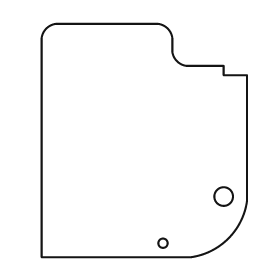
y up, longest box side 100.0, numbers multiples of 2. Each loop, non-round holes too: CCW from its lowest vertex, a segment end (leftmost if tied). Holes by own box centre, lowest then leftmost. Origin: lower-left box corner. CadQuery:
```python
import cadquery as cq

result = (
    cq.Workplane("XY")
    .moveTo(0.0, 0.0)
    .lineTo(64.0, 0.0)
    .threePointArc((80.0, 8.0), (88.0, 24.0))
    .lineTo(88.0, 78.0)
    .lineTo(78.0, 78.0)
    .lineTo(78.0, 82.0)
    .lineTo(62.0, 82.0)
    .threePointArc((58.0, 84.0), (56.0, 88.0))
    .lineTo(56.0, 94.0)
    .threePointArc((54.0, 98.0), (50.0, 100.0))
    .lineTo(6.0, 100.0)
    .threePointArc((2.0, 98.0), (0.0, 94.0))
    .close()
    .moveTo(52.0, 6.0)
    .circle(2.0)
    .moveTo(78.0, 26.0)
    .circle(4.0)
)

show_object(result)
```